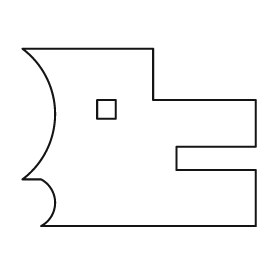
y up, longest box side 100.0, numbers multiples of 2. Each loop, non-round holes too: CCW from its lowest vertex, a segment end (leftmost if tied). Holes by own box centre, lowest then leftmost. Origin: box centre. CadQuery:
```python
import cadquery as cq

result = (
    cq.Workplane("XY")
    .moveTo(-42.0, -38.0)
    .lineTo(50.0, -38.0)
    .lineTo(50.0, -14.0)
    .lineTo(16.0, -14.0)
    .lineTo(16.0, -4.0)
    .lineTo(50.0, -4.0)
    .lineTo(50.0, 16.0)
    .lineTo(6.0, 16.0)
    .lineTo(6.0, 38.0)
    .lineTo(-50.0, 38.0)
    .threePointArc((-36.0, 10.0), (-50.0, -18.0))
    .lineTo(-42.0, -18.0)
    .threePointArc((-36.0, -28.0), (-42.0, -38.0))
    .close()
    .moveTo(-18.0, 8.0)
    .lineTo(-10.0, 8.0)
    .lineTo(-10.0, 16.0)
    .lineTo(-18.0, 16.0)
    .close()
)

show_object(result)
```